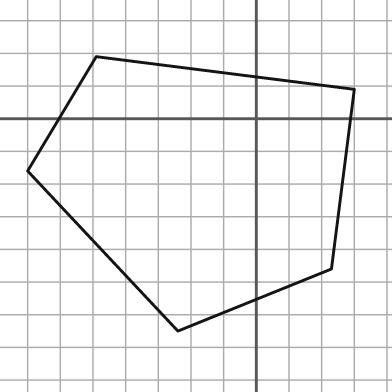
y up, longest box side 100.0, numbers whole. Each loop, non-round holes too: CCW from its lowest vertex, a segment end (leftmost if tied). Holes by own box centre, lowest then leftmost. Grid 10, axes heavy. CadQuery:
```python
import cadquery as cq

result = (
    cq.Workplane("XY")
    .moveTo(-24.0, -65.0)
    .lineTo(23.0, -46.0)
    .lineTo(30.0, 9.0)
    .lineTo(-49.0, 19.0)
    .lineTo(-70.0, -16.0)
    .close()
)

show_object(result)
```